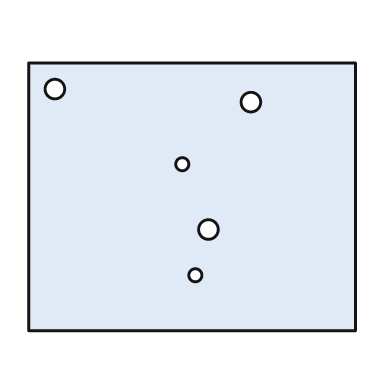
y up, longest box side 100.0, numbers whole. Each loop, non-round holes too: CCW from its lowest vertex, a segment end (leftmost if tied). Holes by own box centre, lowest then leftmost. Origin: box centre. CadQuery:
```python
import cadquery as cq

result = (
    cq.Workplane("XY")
    .moveTo(-50.0, -41.0)
    .lineTo(50.0, -41.0)
    .lineTo(50.0, 41.0)
    .lineTo(-50.0, 41.0)
    .close()
    .moveTo(1.0, -24.0)
    .circle(2.0)
    .moveTo(5.0, -10.0)
    .circle(3.0)
    .moveTo(-3.0, 10.0)
    .circle(2.0)
    .moveTo(18.0, 29.0)
    .circle(3.0)
    .moveTo(-42.0, 33.0)
    .circle(3.0)
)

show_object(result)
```